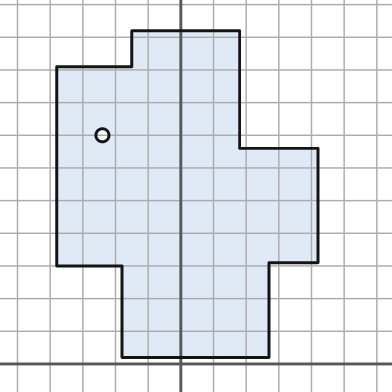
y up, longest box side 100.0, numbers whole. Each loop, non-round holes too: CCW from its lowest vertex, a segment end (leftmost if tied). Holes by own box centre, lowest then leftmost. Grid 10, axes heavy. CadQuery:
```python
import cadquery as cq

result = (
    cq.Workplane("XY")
    .moveTo(-18.0, 2.0)
    .lineTo(27.0, 2.0)
    .lineTo(27.0, 31.0)
    .lineTo(42.0, 31.0)
    .lineTo(42.0, 66.0)
    .lineTo(18.0, 66.0)
    .lineTo(18.0, 102.0)
    .lineTo(-15.0, 102.0)
    .lineTo(-15.0, 91.0)
    .lineTo(-38.0, 91.0)
    .lineTo(-38.0, 30.0)
    .lineTo(-18.0, 30.0)
    .close()
    .moveTo(-24.0, 70.0)
    .circle(2.0)
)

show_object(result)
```